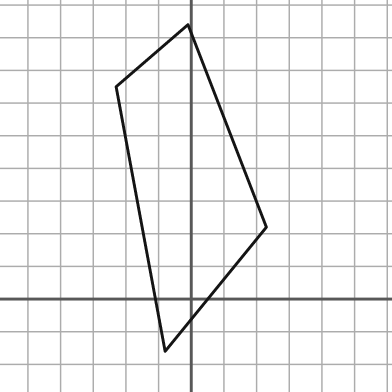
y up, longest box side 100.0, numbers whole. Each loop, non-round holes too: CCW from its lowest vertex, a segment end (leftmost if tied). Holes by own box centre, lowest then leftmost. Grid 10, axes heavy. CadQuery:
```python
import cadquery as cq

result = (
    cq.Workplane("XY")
    .moveTo(-8.0, -16.0)
    .lineTo(23.0, 22.0)
    .lineTo(-1.0, 84.0)
    .lineTo(-23.0, 65.0)
    .close()
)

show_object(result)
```